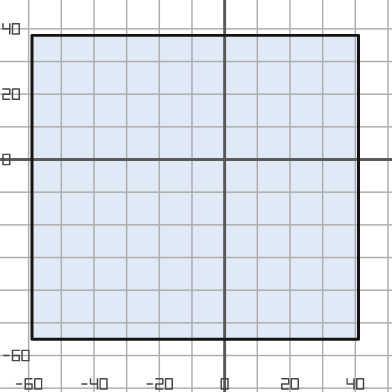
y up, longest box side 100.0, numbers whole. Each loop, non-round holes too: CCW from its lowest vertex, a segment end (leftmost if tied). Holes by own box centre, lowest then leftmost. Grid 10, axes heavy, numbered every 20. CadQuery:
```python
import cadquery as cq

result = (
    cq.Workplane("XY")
    .moveTo(-59.0, -55.0)
    .lineTo(41.0, -55.0)
    .lineTo(41.0, 38.0)
    .lineTo(-59.0, 38.0)
    .close()
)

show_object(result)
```